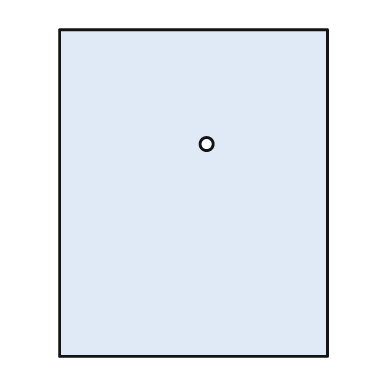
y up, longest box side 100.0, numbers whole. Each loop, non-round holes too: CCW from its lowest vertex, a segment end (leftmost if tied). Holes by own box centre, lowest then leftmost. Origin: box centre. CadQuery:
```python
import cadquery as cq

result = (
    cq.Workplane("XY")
    .moveTo(-41.0, -50.0)
    .lineTo(41.0, -50.0)
    .lineTo(41.0, 50.0)
    .lineTo(-41.0, 50.0)
    .close()
    .moveTo(4.0, 15.0)
    .circle(2.0)
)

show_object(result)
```